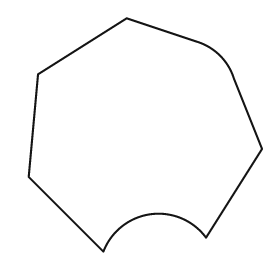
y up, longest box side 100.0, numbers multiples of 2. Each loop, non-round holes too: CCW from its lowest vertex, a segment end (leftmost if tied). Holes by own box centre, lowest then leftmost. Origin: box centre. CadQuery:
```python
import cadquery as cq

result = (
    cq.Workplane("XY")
    .moveTo(-18.0, -50.0)
    .threePointArc((2.0, -34.0), (26.0, -44.0))
    .lineTo(50.0, -6.0)
    .lineTo(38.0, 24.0)
    .threePointArc((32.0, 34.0), (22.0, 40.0))
    .lineTo(-8.0, 50.0)
    .lineTo(-46.0, 26.0)
    .lineTo(-50.0, -18.0)
    .close()
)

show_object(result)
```